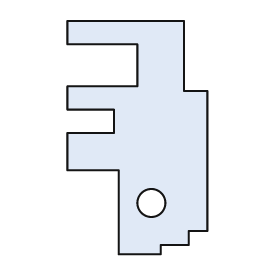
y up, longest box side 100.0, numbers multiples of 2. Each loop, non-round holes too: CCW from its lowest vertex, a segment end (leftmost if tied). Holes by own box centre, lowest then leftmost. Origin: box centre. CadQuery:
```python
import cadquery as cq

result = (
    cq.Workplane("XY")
    .moveTo(-8.0, -50.0)
    .lineTo(10.0, -50.0)
    .lineTo(10.0, -46.0)
    .lineTo(22.0, -46.0)
    .lineTo(22.0, -40.0)
    .lineTo(30.0, -40.0)
    .lineTo(30.0, 20.0)
    .lineTo(20.0, 20.0)
    .lineTo(20.0, 50.0)
    .lineTo(-30.0, 50.0)
    .lineTo(-30.0, 40.0)
    .lineTo(0.0, 40.0)
    .lineTo(0.0, 22.0)
    .lineTo(-30.0, 22.0)
    .lineTo(-30.0, 12.0)
    .lineTo(-10.0, 12.0)
    .lineTo(-10.0, 2.0)
    .lineTo(-30.0, 2.0)
    .lineTo(-30.0, -14.0)
    .lineTo(-8.0, -14.0)
    .close()
    .moveTo(6.0, -28.0)
    .circle(6.0)
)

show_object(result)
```